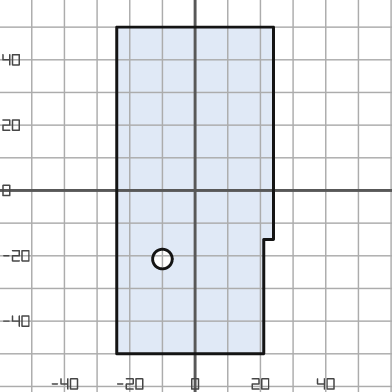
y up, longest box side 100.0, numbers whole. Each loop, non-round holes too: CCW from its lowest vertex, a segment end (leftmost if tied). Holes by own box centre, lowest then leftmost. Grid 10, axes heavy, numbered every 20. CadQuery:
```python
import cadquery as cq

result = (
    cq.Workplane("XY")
    .moveTo(-24.0, -50.0)
    .lineTo(21.0, -50.0)
    .lineTo(21.0, -15.0)
    .lineTo(24.0, -15.0)
    .lineTo(24.0, 50.0)
    .lineTo(-24.0, 50.0)
    .close()
    .moveTo(-10.0, -21.0)
    .circle(3.0)
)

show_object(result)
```